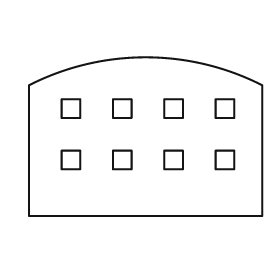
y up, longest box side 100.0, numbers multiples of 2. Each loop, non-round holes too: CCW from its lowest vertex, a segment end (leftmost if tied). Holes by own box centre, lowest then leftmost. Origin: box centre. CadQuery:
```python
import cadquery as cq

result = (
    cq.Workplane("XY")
    .moveTo(-50.0, -34.0)
    .lineTo(50.0, -34.0)
    .lineTo(50.0, 22.0)
    .threePointArc((0.0, 34.0), (-50.0, 22.0))
    .close()
    .moveTo(-36.0, -14.0)
    .lineTo(-28.0, -14.0)
    .lineTo(-28.0, -6.0)
    .lineTo(-36.0, -6.0)
    .close()
    .moveTo(-14.0, -14.0)
    .lineTo(-6.0, -14.0)
    .lineTo(-6.0, -6.0)
    .lineTo(-14.0, -6.0)
    .close()
    .moveTo(8.0, -14.0)
    .lineTo(16.0, -14.0)
    .lineTo(16.0, -6.0)
    .lineTo(8.0, -6.0)
    .close()
    .moveTo(30.0, -14.0)
    .lineTo(38.0, -14.0)
    .lineTo(38.0, -6.0)
    .lineTo(30.0, -6.0)
    .close()
    .moveTo(-36.0, 8.0)
    .lineTo(-28.0, 8.0)
    .lineTo(-28.0, 16.0)
    .lineTo(-36.0, 16.0)
    .close()
    .moveTo(-14.0, 8.0)
    .lineTo(-6.0, 8.0)
    .lineTo(-6.0, 16.0)
    .lineTo(-14.0, 16.0)
    .close()
    .moveTo(8.0, 8.0)
    .lineTo(16.0, 8.0)
    .lineTo(16.0, 16.0)
    .lineTo(8.0, 16.0)
    .close()
    .moveTo(30.0, 8.0)
    .lineTo(38.0, 8.0)
    .lineTo(38.0, 16.0)
    .lineTo(30.0, 16.0)
    .close()
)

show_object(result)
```